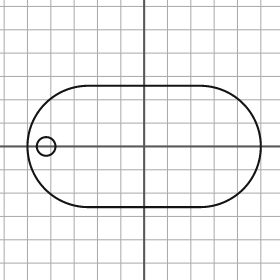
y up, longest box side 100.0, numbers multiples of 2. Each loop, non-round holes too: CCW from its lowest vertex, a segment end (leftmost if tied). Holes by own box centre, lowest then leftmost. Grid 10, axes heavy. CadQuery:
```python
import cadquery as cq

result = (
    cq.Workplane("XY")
    .moveTo(-24.0, -26.0)
    .lineTo(24.0, -26.0)
    .threePointArc((50.0, 0.0), (24.0, 26.0))
    .lineTo(-24.0, 26.0)
    .threePointArc((-50.0, 0.0), (-24.0, -26.0))
    .close()
    .moveTo(-42.0, 0.0)
    .circle(4.0)
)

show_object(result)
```